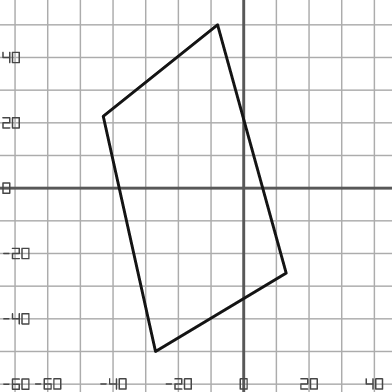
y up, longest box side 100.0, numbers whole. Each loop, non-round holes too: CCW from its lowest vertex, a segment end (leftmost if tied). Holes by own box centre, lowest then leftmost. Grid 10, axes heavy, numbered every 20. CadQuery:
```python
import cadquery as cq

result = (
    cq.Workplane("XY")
    .moveTo(-27.0, -50.0)
    .lineTo(13.0, -26.0)
    .lineTo(-8.0, 50.0)
    .lineTo(-43.0, 22.0)
    .close()
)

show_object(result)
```